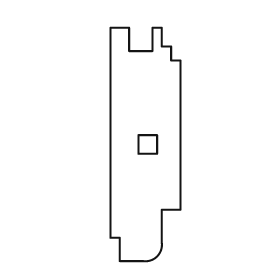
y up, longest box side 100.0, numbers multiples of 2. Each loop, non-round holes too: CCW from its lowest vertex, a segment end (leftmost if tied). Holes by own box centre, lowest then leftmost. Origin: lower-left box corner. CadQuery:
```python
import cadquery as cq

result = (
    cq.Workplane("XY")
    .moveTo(4.0, 0.0)
    .lineTo(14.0, 0.0)
    .threePointArc((20.0, 2.0), (22.0, 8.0))
    .lineTo(22.0, 22.0)
    .lineTo(30.0, 22.0)
    .lineTo(30.0, 86.0)
    .lineTo(26.0, 86.0)
    .lineTo(26.0, 92.0)
    .lineTo(22.0, 92.0)
    .lineTo(22.0, 100.0)
    .lineTo(18.0, 100.0)
    .lineTo(18.0, 90.0)
    .lineTo(8.0, 90.0)
    .lineTo(8.0, 100.0)
    .lineTo(0.0, 100.0)
    .lineTo(0.0, 10.0)
    .lineTo(4.0, 10.0)
    .close()
    .moveTo(12.0, 46.0)
    .lineTo(20.0, 46.0)
    .lineTo(20.0, 54.0)
    .lineTo(12.0, 54.0)
    .close()
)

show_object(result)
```